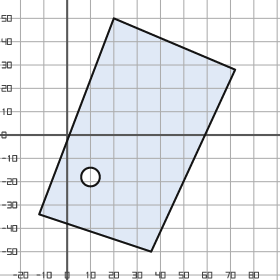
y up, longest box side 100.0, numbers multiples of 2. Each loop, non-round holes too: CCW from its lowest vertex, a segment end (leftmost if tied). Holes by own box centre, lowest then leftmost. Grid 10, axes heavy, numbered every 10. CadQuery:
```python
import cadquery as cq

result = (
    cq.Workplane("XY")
    .moveTo(36.0, -50.0)
    .lineTo(72.0, 28.0)
    .lineTo(20.0, 50.0)
    .lineTo(-12.0, -34.0)
    .close()
    .moveTo(10.0, -18.0)
    .circle(4.0)
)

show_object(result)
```